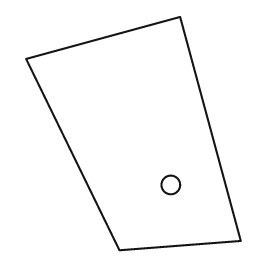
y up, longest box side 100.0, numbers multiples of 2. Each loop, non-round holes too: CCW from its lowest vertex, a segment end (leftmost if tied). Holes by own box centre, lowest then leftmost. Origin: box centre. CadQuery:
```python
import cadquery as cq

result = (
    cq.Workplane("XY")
    .moveTo(-6.0, -50.0)
    .lineTo(46.0, -46.0)
    .lineTo(20.0, 50.0)
    .lineTo(-46.0, 32.0)
    .close()
    .moveTo(16.0, -22.0)
    .circle(4.0)
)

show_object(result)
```